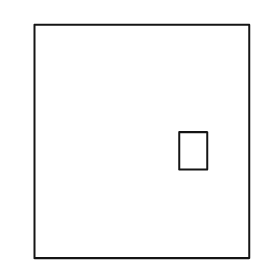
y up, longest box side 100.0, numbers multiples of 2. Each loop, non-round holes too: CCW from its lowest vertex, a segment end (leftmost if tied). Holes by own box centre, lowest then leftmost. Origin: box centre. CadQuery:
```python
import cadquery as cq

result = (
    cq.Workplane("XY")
    .moveTo(-46.0, -50.0)
    .lineTo(46.0, -50.0)
    .lineTo(46.0, 50.0)
    .lineTo(-46.0, 50.0)
    .close()
    .moveTo(16.0, -12.0)
    .lineTo(28.0, -12.0)
    .lineTo(28.0, 4.0)
    .lineTo(16.0, 4.0)
    .close()
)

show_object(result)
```